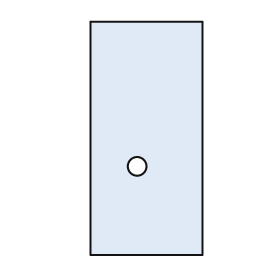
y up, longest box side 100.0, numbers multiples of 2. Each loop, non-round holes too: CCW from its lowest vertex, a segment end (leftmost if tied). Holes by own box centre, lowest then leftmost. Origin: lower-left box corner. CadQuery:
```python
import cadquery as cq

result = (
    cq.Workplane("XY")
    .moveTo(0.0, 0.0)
    .lineTo(48.0, 0.0)
    .lineTo(48.0, 100.0)
    .lineTo(0.0, 100.0)
    .close()
    .moveTo(20.0, 38.0)
    .circle(4.0)
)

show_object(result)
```